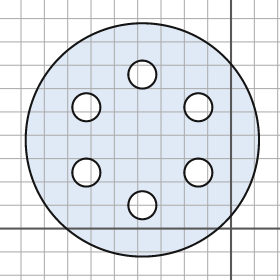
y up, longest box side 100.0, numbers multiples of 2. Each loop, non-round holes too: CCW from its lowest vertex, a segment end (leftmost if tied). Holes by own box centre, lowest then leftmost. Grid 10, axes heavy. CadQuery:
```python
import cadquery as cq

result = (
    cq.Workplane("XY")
    .moveTo(-38.0, 38.0)
    .circle(50.0)
    .moveTo(-38.0, 10.0)
    .circle(6.0)
    .moveTo(-62.0, 24.0)
    .circle(6.0)
    .moveTo(-14.0, 24.0)
    .circle(6.0)
    .moveTo(-62.0, 52.0)
    .circle(6.0)
    .moveTo(-14.0, 52.0)
    .circle(6.0)
    .moveTo(-38.0, 66.0)
    .circle(6.0)
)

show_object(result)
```